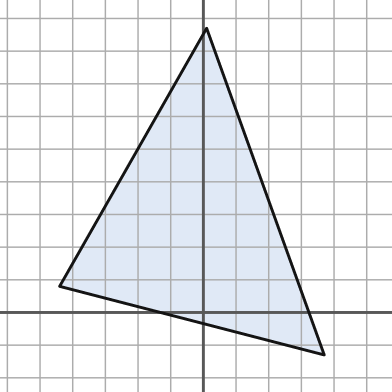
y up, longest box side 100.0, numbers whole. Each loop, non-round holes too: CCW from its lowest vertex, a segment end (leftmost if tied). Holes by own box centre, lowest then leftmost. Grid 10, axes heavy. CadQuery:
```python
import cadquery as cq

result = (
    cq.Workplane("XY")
    .moveTo(37.0, -13.0)
    .lineTo(1.0, 87.0)
    .lineTo(-44.0, 8.0)
    .close()
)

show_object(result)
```